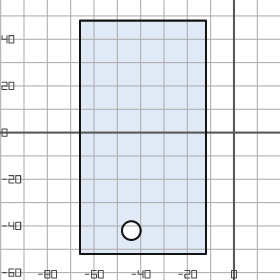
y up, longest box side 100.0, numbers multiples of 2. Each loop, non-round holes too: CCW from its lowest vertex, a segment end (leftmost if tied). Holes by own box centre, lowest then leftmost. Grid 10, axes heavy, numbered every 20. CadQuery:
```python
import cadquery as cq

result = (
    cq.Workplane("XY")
    .moveTo(-66.0, -52.0)
    .lineTo(-12.0, -52.0)
    .lineTo(-12.0, 48.0)
    .lineTo(-66.0, 48.0)
    .close()
    .moveTo(-44.0, -42.0)
    .circle(4.0)
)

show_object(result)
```